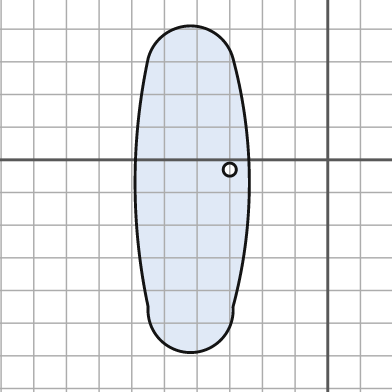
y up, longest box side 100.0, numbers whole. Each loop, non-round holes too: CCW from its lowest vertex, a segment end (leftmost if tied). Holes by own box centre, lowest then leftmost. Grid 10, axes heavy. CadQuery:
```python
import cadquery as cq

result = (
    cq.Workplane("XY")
    .moveTo(-55.0, -45.0)
    .threePointArc((-42.0, -59.0), (-29.0, -45.0))
    .threePointArc((-24.0, -7.0), (-29.0, 31.0))
    .threePointArc((-42.0, 41.0), (-55.0, 31.0))
    .threePointArc((-59.0, -7.0), (-55.0, -45.0))
    .close()
    .moveTo(-30.0, -3.0)
    .circle(2.0)
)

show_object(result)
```